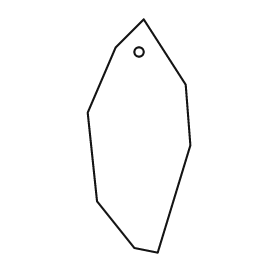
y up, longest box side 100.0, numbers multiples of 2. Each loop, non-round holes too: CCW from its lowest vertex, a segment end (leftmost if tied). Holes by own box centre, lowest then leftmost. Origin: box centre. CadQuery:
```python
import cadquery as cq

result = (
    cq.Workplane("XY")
    .moveTo(8.0, -50.0)
    .lineTo(22.0, -4.0)
    .lineTo(20.0, 22.0)
    .lineTo(2.0, 50.0)
    .lineTo(-10.0, 38.0)
    .lineTo(-22.0, 10.0)
    .lineTo(-18.0, -28.0)
    .lineTo(-2.0, -48.0)
    .close()
    .moveTo(0.0, 36.0)
    .circle(2.0)
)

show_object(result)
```